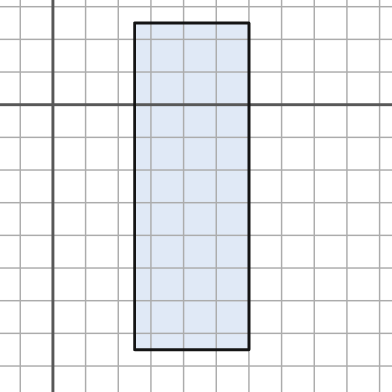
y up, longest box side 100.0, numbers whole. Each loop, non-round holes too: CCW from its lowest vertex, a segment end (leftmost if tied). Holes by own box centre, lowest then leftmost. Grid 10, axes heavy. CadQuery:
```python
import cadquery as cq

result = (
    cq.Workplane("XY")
    .moveTo(25.0, -75.0)
    .lineTo(60.0, -75.0)
    .lineTo(60.0, 25.0)
    .lineTo(25.0, 25.0)
    .close()
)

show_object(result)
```